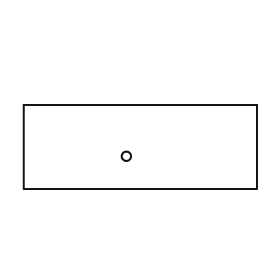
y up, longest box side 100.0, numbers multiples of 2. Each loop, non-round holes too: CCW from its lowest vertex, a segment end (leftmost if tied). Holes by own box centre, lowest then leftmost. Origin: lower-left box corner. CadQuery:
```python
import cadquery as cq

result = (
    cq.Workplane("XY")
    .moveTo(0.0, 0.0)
    .lineTo(100.0, 0.0)
    .lineTo(100.0, 36.0)
    .lineTo(0.0, 36.0)
    .close()
    .moveTo(44.0, 14.0)
    .circle(2.0)
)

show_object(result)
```